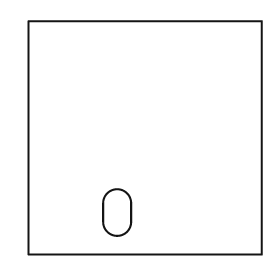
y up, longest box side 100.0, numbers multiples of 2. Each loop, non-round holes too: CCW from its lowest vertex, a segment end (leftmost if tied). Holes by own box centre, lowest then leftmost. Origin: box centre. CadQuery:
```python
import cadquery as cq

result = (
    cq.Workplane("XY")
    .moveTo(-50.0, -50.0)
    .lineTo(50.0, -50.0)
    .lineTo(50.0, 50.0)
    .lineTo(-50.0, 50.0)
    .close()
    .moveTo(-18.0, -36.0)
    .threePointArc((-12.0, -42.0), (-6.0, -36.0))
    .lineTo(-6.0, -28.0)
    .threePointArc((-12.0, -22.0), (-18.0, -28.0))
    .close()
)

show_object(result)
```